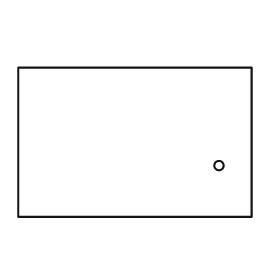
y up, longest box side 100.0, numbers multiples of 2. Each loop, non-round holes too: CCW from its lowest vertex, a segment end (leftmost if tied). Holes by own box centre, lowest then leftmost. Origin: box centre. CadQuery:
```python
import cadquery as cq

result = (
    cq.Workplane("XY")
    .moveTo(-50.0, -32.0)
    .lineTo(50.0, -32.0)
    .lineTo(50.0, 32.0)
    .lineTo(-50.0, 32.0)
    .close()
    .moveTo(36.0, -10.0)
    .circle(2.0)
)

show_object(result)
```